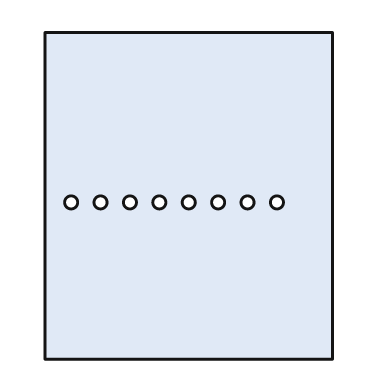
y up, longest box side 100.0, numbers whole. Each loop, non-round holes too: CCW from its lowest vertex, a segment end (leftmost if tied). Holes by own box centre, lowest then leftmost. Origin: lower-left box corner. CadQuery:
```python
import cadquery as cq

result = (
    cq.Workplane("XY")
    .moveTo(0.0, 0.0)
    .lineTo(88.0, 0.0)
    .lineTo(88.0, 100.0)
    .lineTo(0.0, 100.0)
    .close()
    .moveTo(8.0, 48.0)
    .circle(2.0)
    .moveTo(17.0, 48.0)
    .circle(2.0)
    .moveTo(26.0, 48.0)
    .circle(2.0)
    .moveTo(35.0, 48.0)
    .circle(2.0)
    .moveTo(44.0, 48.0)
    .circle(2.0)
    .moveTo(53.0, 48.0)
    .circle(2.0)
    .moveTo(62.0, 48.0)
    .circle(2.0)
    .moveTo(71.0, 48.0)
    .circle(2.0)
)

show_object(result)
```